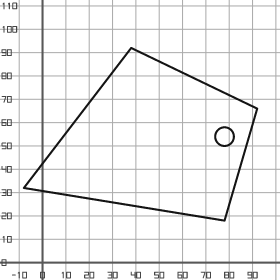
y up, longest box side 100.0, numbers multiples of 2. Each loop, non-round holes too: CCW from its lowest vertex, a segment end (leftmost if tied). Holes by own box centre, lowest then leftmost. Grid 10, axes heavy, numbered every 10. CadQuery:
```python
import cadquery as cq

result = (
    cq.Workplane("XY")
    .moveTo(78.0, 18.0)
    .lineTo(92.0, 66.0)
    .lineTo(38.0, 92.0)
    .lineTo(-8.0, 32.0)
    .close()
    .moveTo(78.0, 54.0)
    .circle(4.0)
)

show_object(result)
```